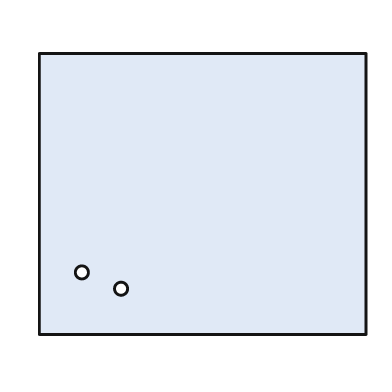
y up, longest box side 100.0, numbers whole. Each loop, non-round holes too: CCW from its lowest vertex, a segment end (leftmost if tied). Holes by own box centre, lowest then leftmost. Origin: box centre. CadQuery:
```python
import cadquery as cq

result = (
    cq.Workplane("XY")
    .moveTo(-50.0, -43.0)
    .lineTo(50.0, -43.0)
    .lineTo(50.0, 43.0)
    .lineTo(-50.0, 43.0)
    .close()
    .moveTo(-25.0, -29.0)
    .circle(2.0)
    .moveTo(-37.0, -24.0)
    .circle(2.0)
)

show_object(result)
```